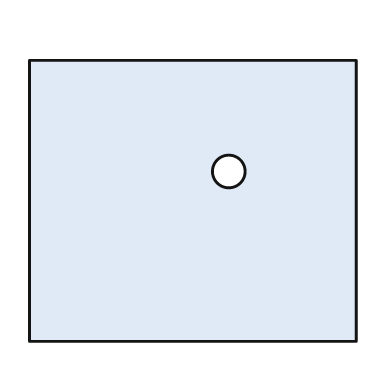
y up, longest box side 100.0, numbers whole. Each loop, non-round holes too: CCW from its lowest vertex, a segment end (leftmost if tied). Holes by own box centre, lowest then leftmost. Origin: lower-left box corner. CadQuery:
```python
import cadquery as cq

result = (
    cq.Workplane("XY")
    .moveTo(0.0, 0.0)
    .lineTo(100.0, 0.0)
    .lineTo(100.0, 86.0)
    .lineTo(0.0, 86.0)
    .close()
    .moveTo(61.0, 52.0)
    .circle(5.0)
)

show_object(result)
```